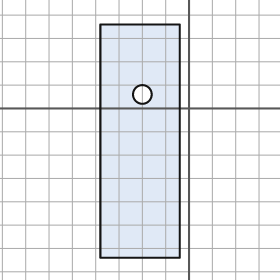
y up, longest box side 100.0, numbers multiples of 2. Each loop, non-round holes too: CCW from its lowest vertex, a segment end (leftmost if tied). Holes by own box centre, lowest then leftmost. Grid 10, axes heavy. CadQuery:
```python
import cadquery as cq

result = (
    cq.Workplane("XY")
    .moveTo(-38.0, -64.0)
    .lineTo(-4.0, -64.0)
    .lineTo(-4.0, 36.0)
    .lineTo(-38.0, 36.0)
    .close()
    .moveTo(-20.0, 6.0)
    .circle(4.0)
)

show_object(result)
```